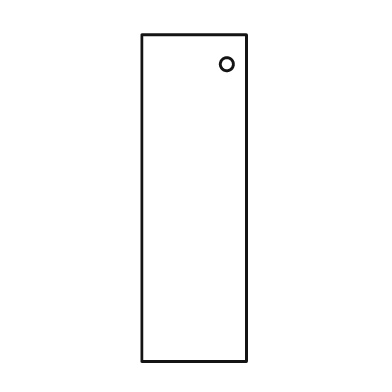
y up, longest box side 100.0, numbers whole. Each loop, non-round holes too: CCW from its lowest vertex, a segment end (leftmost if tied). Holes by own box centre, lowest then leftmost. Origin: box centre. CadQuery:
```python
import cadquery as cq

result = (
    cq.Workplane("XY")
    .moveTo(-16.0, -50.0)
    .lineTo(16.0, -50.0)
    .lineTo(16.0, 50.0)
    .lineTo(-16.0, 50.0)
    .close()
    .moveTo(10.0, 41.0)
    .circle(2.0)
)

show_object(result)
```